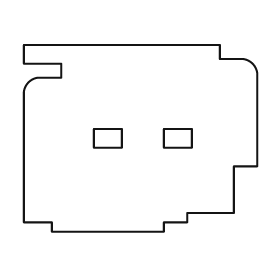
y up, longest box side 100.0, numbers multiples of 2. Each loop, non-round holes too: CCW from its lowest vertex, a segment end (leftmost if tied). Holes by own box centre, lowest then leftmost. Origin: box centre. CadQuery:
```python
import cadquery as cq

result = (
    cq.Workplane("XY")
    .moveTo(-38.0, -40.0)
    .lineTo(10.0, -40.0)
    .lineTo(10.0, -36.0)
    .lineTo(20.0, -36.0)
    .lineTo(20.0, -32.0)
    .lineTo(40.0, -32.0)
    .lineTo(40.0, -12.0)
    .lineTo(50.0, -12.0)
    .lineTo(50.0, 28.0)
    .threePointArc((48.0, 32.0), (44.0, 34.0))
    .lineTo(34.0, 34.0)
    .lineTo(34.0, 40.0)
    .lineTo(-50.0, 40.0)
    .lineTo(-50.0, 32.0)
    .lineTo(-34.0, 32.0)
    .lineTo(-34.0, 26.0)
    .lineTo(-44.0, 26.0)
    .threePointArc((-48.0, 24.0), (-50.0, 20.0))
    .lineTo(-50.0, -36.0)
    .lineTo(-38.0, -36.0)
    .close()
    .moveTo(-20.0, -4.0)
    .lineTo(-8.0, -4.0)
    .lineTo(-8.0, 4.0)
    .lineTo(-20.0, 4.0)
    .close()
    .moveTo(10.0, -4.0)
    .lineTo(22.0, -4.0)
    .lineTo(22.0, 4.0)
    .lineTo(10.0, 4.0)
    .close()
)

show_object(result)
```